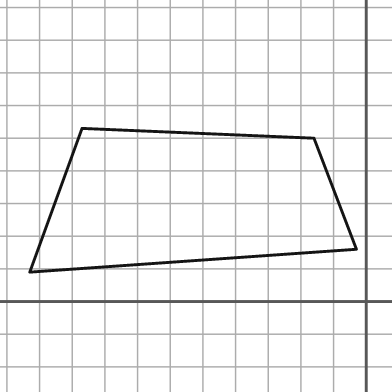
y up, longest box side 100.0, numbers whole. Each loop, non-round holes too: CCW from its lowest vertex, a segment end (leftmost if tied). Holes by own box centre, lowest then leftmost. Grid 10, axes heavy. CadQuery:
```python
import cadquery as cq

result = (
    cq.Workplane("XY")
    .moveTo(-103.0, 9.0)
    .lineTo(-3.0, 16.0)
    .lineTo(-16.0, 50.0)
    .lineTo(-87.0, 53.0)
    .close()
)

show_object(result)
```